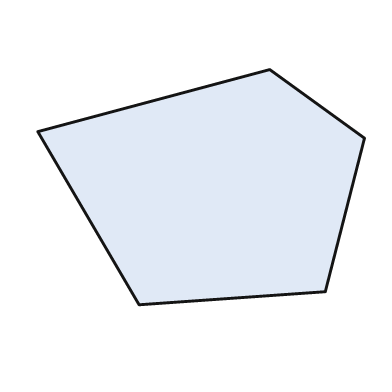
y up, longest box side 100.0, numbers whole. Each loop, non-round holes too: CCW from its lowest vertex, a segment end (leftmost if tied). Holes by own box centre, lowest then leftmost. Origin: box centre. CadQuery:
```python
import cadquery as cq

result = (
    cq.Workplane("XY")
    .moveTo(-19.0, -36.0)
    .lineTo(38.0, -32.0)
    .lineTo(50.0, 15.0)
    .lineTo(21.0, 36.0)
    .lineTo(-50.0, 17.0)
    .close()
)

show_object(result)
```